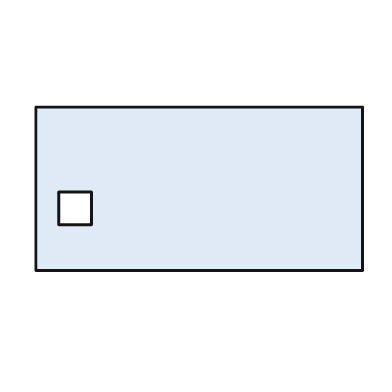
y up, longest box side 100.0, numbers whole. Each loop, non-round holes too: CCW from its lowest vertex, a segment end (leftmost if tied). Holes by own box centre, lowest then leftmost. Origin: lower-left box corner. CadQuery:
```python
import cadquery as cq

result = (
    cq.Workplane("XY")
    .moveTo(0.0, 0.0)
    .lineTo(100.0, 0.0)
    .lineTo(100.0, 50.0)
    .lineTo(0.0, 50.0)
    .close()
    .moveTo(7.0, 14.0)
    .lineTo(17.0, 14.0)
    .lineTo(17.0, 24.0)
    .lineTo(7.0, 24.0)
    .close()
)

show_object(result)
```